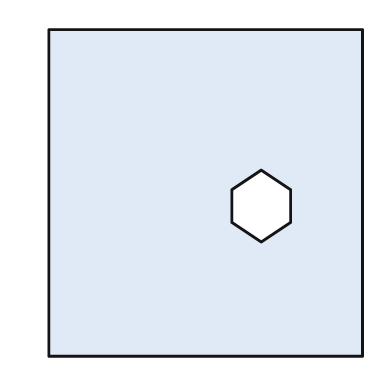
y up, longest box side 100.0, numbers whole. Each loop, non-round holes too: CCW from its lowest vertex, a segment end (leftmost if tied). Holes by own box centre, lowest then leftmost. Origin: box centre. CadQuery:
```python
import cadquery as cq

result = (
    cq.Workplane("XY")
    .moveTo(-48.0, -50.0)
    .lineTo(48.0, -50.0)
    .lineTo(48.0, 50.0)
    .lineTo(-48.0, 50.0)
    .close()
    .moveTo(17.0, -15.0)
    .lineTo(26.0, -9.0)
    .lineTo(26.0, 1.0)
    .lineTo(17.0, 7.0)
    .lineTo(8.0, 1.0)
    .lineTo(8.0, -9.0)
    .close()
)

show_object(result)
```